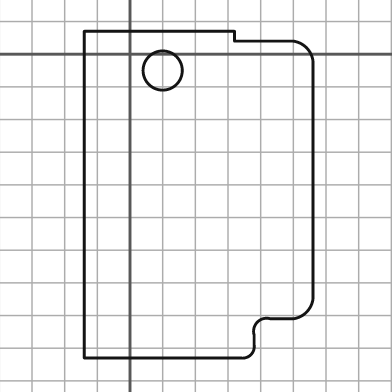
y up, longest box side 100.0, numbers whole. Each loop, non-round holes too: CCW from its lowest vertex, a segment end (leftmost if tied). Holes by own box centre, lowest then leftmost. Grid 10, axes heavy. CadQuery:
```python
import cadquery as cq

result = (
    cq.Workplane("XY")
    .moveTo(-14.0, -93.0)
    .lineTo(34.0, -93.0)
    .threePointArc((37.0, -92.0), (38.0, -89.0))
    .lineTo(38.0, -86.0)
    .threePointArc((39.0, -82.0), (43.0, -81.0))
    .lineTo(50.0, -81.0)
    .threePointArc((54.0, -79.0), (56.0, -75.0))
    .lineTo(56.0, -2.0)
    .threePointArc((54.0, 2.0), (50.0, 4.0))
    .lineTo(32.0, 4.0)
    .lineTo(32.0, 7.0)
    .lineTo(-14.0, 7.0)
    .close()
    .moveTo(10.0, -5.0)
    .circle(6.0)
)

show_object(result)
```